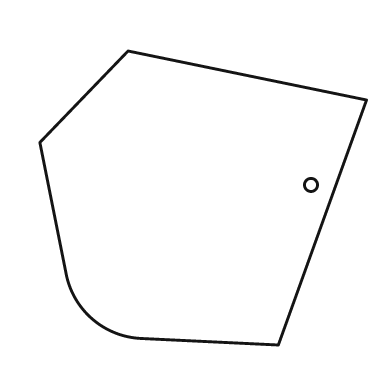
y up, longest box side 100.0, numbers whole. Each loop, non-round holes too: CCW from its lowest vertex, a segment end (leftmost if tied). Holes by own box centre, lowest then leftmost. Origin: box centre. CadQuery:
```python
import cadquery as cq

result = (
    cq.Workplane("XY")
    .moveTo(23.0, -45.0)
    .lineTo(50.0, 30.0)
    .lineTo(-23.0, 45.0)
    .lineTo(-50.0, 17.0)
    .lineTo(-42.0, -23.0)
    .threePointArc((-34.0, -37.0), (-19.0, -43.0))
    .close()
    .moveTo(33.0, 4.0)
    .circle(2.0)
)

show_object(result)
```